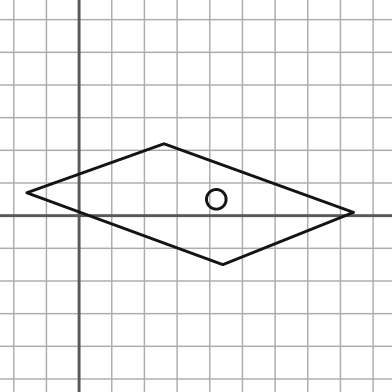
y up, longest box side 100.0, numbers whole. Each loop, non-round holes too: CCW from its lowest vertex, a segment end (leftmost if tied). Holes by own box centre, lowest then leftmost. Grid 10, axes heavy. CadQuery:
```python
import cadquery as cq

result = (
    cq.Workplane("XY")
    .moveTo(44.0, -15.0)
    .lineTo(84.0, 1.0)
    .lineTo(26.0, 22.0)
    .lineTo(-16.0, 7.0)
    .close()
    .moveTo(42.0, 5.0)
    .circle(3.0)
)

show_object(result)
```